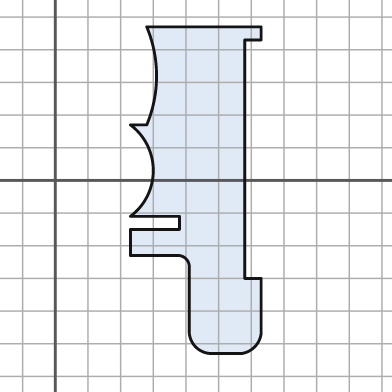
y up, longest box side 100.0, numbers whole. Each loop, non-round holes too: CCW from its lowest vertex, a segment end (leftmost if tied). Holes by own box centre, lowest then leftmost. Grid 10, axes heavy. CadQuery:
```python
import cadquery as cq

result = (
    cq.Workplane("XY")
    .moveTo(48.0, -53.0)
    .lineTo(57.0, -53.0)
    .threePointArc((61.0, -51.0), (63.0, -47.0))
    .lineTo(63.0, -30.0)
    .lineTo(58.0, -30.0)
    .lineTo(58.0, 43.0)
    .lineTo(63.0, 43.0)
    .lineTo(63.0, 47.0)
    .lineTo(28.0, 47.0)
    .threePointArc((31.0, 32.0), (28.0, 17.0))
    .lineTo(23.0, 17.0)
    .threePointArc((30.0, 3.0), (23.0, -11.0))
    .lineTo(38.0, -11.0)
    .lineTo(38.0, -15.0)
    .lineTo(23.0, -15.0)
    .lineTo(23.0, -23.0)
    .lineTo(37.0, -23.0)
    .threePointArc((40.0, -24.0), (41.0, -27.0))
    .lineTo(41.0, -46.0)
    .threePointArc((43.0, -51.0), (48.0, -53.0))
    .close()
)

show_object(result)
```